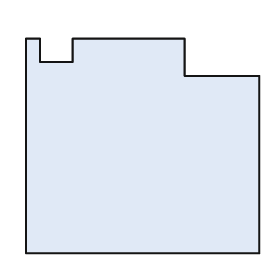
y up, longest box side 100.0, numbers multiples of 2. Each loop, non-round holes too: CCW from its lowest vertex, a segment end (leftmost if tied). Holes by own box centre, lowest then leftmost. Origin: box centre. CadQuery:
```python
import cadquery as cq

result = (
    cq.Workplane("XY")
    .moveTo(-50.0, -46.0)
    .lineTo(50.0, -46.0)
    .lineTo(50.0, 30.0)
    .lineTo(18.0, 30.0)
    .lineTo(18.0, 46.0)
    .lineTo(-30.0, 46.0)
    .lineTo(-30.0, 36.0)
    .lineTo(-44.0, 36.0)
    .lineTo(-44.0, 46.0)
    .lineTo(-50.0, 46.0)
    .close()
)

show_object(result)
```